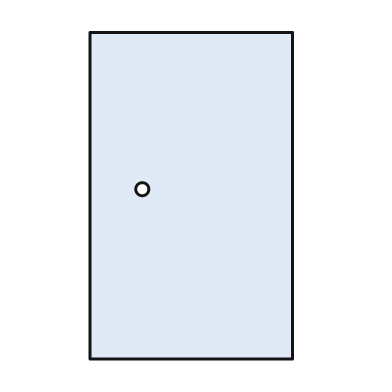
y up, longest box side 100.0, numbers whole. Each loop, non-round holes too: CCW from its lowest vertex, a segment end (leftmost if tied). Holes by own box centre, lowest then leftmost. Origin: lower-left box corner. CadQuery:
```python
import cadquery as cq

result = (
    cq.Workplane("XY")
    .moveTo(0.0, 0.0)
    .lineTo(62.0, 0.0)
    .lineTo(62.0, 100.0)
    .lineTo(0.0, 100.0)
    .close()
    .moveTo(16.0, 52.0)
    .circle(2.0)
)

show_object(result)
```